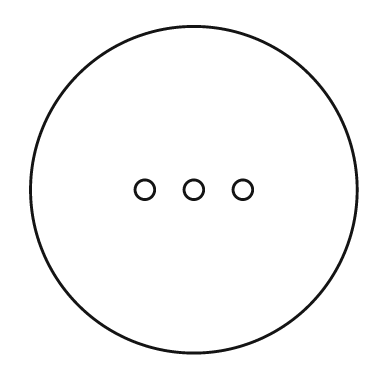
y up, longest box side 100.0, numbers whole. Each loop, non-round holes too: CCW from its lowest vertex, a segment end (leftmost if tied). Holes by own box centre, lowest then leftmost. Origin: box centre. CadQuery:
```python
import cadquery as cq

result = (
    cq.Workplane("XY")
    .moveTo(0.0, 0.0)
    .circle(50.0)
    .moveTo(-15.0, 0.0)
    .circle(3.0)
    .moveTo(0.0, 0.0)
    .circle(3.0)
    .moveTo(15.0, 0.0)
    .circle(3.0)
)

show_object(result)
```